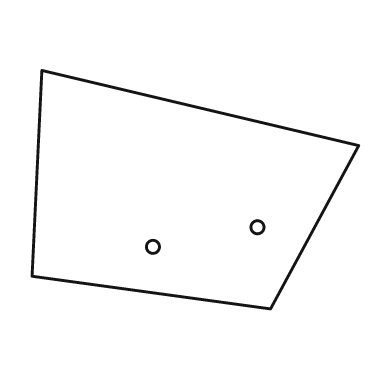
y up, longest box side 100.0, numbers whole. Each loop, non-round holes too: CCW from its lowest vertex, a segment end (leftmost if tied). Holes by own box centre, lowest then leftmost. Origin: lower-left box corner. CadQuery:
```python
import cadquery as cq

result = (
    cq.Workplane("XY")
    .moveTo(73.0, 0.0)
    .lineTo(100.0, 50.0)
    .lineTo(3.0, 73.0)
    .lineTo(0.0, 10.0)
    .close()
    .moveTo(37.0, 19.0)
    .circle(2.0)
    .moveTo(69.0, 25.0)
    .circle(2.0)
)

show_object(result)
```